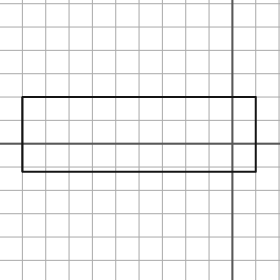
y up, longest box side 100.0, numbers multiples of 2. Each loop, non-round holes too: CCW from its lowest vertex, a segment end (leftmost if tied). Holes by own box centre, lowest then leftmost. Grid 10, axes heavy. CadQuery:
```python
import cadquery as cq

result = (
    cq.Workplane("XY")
    .moveTo(-90.0, -12.0)
    .lineTo(10.0, -12.0)
    .lineTo(10.0, 20.0)
    .lineTo(-90.0, 20.0)
    .close()
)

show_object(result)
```